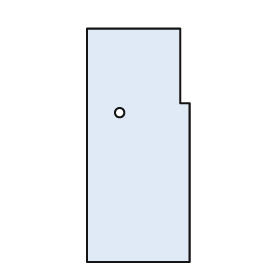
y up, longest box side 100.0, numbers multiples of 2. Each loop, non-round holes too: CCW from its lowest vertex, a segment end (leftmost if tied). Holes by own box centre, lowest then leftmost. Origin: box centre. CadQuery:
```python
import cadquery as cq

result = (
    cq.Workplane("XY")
    .moveTo(-22.0, -50.0)
    .lineTo(22.0, -50.0)
    .lineTo(22.0, 18.0)
    .lineTo(18.0, 18.0)
    .lineTo(18.0, 50.0)
    .lineTo(-22.0, 50.0)
    .close()
    .moveTo(-8.0, 14.0)
    .circle(2.0)
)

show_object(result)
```